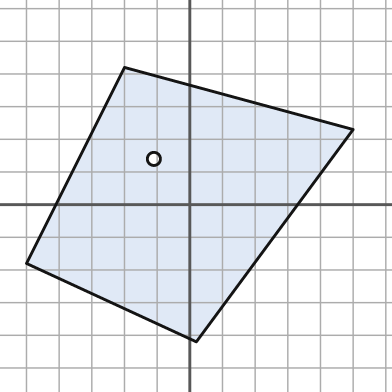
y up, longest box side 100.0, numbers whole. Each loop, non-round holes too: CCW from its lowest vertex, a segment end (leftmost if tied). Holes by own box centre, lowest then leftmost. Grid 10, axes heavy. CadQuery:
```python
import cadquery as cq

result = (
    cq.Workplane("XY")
    .moveTo(2.0, -42.0)
    .lineTo(50.0, 23.0)
    .lineTo(-20.0, 42.0)
    .lineTo(-50.0, -18.0)
    .close()
    .moveTo(-11.0, 14.0)
    .circle(2.0)
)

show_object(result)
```